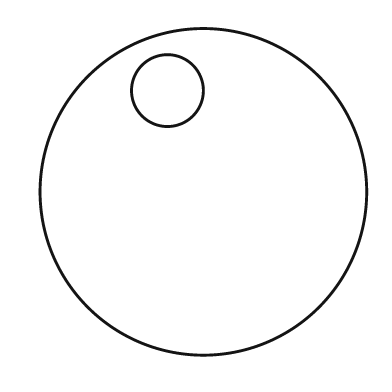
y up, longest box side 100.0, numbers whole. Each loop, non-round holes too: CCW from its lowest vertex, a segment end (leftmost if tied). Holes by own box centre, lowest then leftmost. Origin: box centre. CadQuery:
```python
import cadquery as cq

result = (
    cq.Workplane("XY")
    .moveTo(0.0, 0.0)
    .circle(50.0)
    .moveTo(-11.0, 31.0)
    .circle(11.0)
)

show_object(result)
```